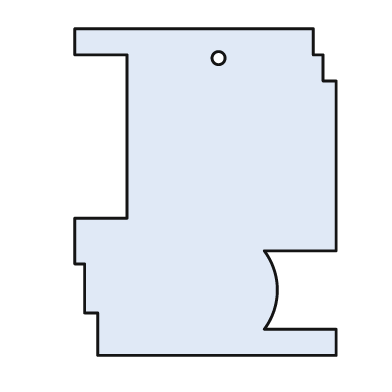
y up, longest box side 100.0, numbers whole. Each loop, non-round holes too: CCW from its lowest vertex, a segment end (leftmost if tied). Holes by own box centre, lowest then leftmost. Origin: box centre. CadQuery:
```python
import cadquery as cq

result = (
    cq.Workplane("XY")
    .moveTo(-33.0, -50.0)
    .lineTo(40.0, -50.0)
    .lineTo(40.0, -42.0)
    .lineTo(18.0, -42.0)
    .threePointArc((22.0, -30.0), (18.0, -18.0))
    .lineTo(40.0, -18.0)
    .lineTo(40.0, 34.0)
    .lineTo(36.0, 34.0)
    .lineTo(36.0, 42.0)
    .lineTo(33.0, 42.0)
    .lineTo(33.0, 50.0)
    .lineTo(-40.0, 50.0)
    .lineTo(-40.0, 42.0)
    .lineTo(-24.0, 42.0)
    .lineTo(-24.0, -8.0)
    .lineTo(-40.0, -8.0)
    .lineTo(-40.0, -22.0)
    .lineTo(-37.0, -22.0)
    .lineTo(-37.0, -37.0)
    .lineTo(-33.0, -37.0)
    .close()
    .moveTo(4.0, 41.0)
    .circle(2.0)
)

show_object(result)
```